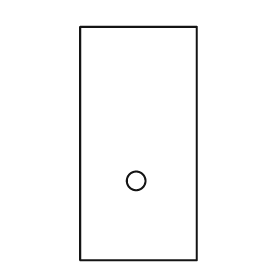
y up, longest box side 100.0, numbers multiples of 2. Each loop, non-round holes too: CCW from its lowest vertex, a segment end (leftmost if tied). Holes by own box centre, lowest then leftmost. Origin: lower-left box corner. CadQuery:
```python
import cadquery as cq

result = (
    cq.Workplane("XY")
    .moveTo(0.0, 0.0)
    .lineTo(50.0, 0.0)
    .lineTo(50.0, 100.0)
    .lineTo(0.0, 100.0)
    .close()
    .moveTo(24.0, 34.0)
    .circle(4.0)
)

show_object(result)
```